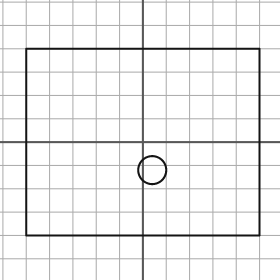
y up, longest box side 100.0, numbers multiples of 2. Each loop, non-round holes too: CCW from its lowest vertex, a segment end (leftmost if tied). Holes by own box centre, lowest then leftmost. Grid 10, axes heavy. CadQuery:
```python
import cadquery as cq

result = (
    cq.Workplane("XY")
    .moveTo(-50.0, -40.0)
    .lineTo(50.0, -40.0)
    .lineTo(50.0, 40.0)
    .lineTo(-50.0, 40.0)
    .close()
    .moveTo(4.0, -12.0)
    .circle(6.0)
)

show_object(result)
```